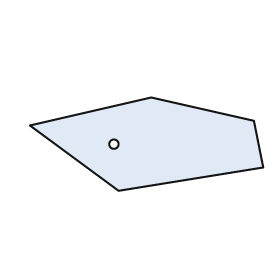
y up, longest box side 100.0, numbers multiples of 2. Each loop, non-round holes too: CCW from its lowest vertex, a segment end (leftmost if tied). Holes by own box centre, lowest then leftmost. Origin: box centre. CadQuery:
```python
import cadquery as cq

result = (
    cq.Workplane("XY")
    .moveTo(-12.0, -20.0)
    .lineTo(50.0, -10.0)
    .lineTo(46.0, 10.0)
    .lineTo(2.0, 20.0)
    .lineTo(-50.0, 8.0)
    .close()
    .moveTo(-14.0, 0.0)
    .circle(2.0)
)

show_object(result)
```